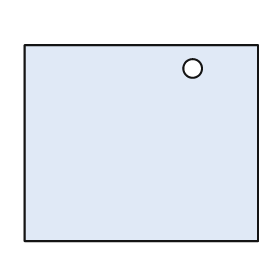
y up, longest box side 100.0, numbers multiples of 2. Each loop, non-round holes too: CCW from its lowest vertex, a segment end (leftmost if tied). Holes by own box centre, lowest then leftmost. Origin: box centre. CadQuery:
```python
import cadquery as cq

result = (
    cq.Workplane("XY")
    .moveTo(-50.0, -42.0)
    .lineTo(50.0, -42.0)
    .lineTo(50.0, 42.0)
    .lineTo(-50.0, 42.0)
    .close()
    .moveTo(22.0, 32.0)
    .circle(4.0)
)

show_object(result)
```